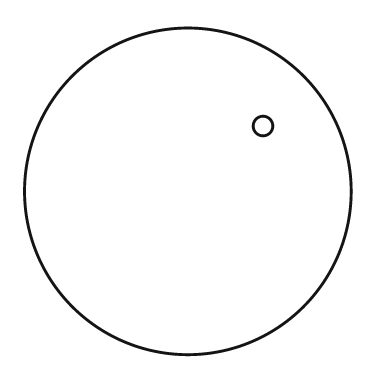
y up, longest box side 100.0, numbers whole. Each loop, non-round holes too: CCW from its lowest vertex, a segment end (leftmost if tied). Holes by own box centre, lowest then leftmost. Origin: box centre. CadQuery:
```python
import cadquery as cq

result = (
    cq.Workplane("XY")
    .moveTo(0.0, 0.0)
    .circle(50.0)
    .moveTo(23.0, 20.0)
    .circle(3.0)
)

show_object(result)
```